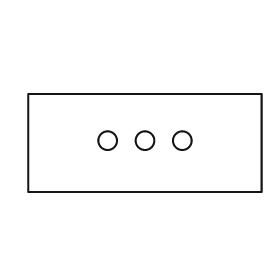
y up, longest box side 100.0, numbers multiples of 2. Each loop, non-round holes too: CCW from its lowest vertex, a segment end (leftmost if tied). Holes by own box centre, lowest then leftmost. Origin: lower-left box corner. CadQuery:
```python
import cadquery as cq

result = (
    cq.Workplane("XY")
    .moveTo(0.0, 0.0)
    .lineTo(100.0, 0.0)
    .lineTo(100.0, 42.0)
    .lineTo(0.0, 42.0)
    .close()
    .moveTo(34.0, 22.0)
    .circle(4.0)
    .moveTo(50.0, 22.0)
    .circle(4.0)
    .moveTo(66.0, 22.0)
    .circle(4.0)
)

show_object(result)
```